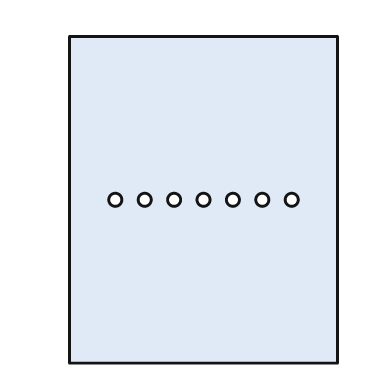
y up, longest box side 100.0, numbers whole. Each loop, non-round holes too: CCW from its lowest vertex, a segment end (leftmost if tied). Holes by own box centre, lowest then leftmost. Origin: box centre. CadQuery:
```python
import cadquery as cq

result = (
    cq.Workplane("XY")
    .moveTo(-41.0, -50.0)
    .lineTo(41.0, -50.0)
    .lineTo(41.0, 50.0)
    .lineTo(-41.0, 50.0)
    .close()
    .moveTo(-27.0, 0.0)
    .circle(2.0)
    .moveTo(-18.0, 0.0)
    .circle(2.0)
    .moveTo(-9.0, 0.0)
    .circle(2.0)
    .moveTo(0.0, 0.0)
    .circle(2.0)
    .moveTo(9.0, 0.0)
    .circle(2.0)
    .moveTo(18.0, 0.0)
    .circle(2.0)
    .moveTo(27.0, 0.0)
    .circle(2.0)
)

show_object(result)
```